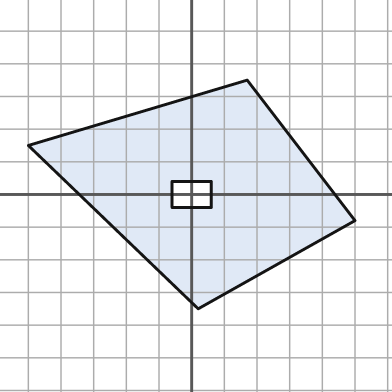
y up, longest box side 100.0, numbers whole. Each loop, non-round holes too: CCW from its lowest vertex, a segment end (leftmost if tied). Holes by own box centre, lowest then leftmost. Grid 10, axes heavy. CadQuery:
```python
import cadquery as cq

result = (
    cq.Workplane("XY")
    .moveTo(2.0, -35.0)
    .lineTo(50.0, -8.0)
    .lineTo(17.0, 35.0)
    .lineTo(-50.0, 15.0)
    .close()
    .moveTo(-6.0, -4.0)
    .lineTo(6.0, -4.0)
    .lineTo(6.0, 4.0)
    .lineTo(-6.0, 4.0)
    .close()
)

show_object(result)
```